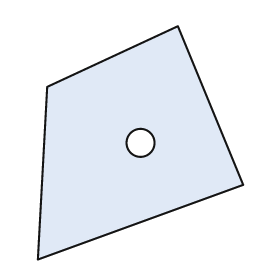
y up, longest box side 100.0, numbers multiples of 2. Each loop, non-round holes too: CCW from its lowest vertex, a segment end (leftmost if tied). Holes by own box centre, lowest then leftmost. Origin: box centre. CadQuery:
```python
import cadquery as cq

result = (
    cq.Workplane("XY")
    .moveTo(-44.0, -50.0)
    .lineTo(44.0, -18.0)
    .lineTo(16.0, 50.0)
    .lineTo(-40.0, 24.0)
    .close()
    .moveTo(0.0, 0.0)
    .circle(6.0)
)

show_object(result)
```